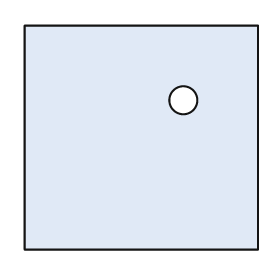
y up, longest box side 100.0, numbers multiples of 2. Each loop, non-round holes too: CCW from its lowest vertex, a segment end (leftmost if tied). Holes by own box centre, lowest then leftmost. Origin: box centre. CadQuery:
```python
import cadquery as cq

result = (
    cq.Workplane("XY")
    .moveTo(-50.0, -48.0)
    .lineTo(50.0, -48.0)
    .lineTo(50.0, 48.0)
    .lineTo(-50.0, 48.0)
    .close()
    .moveTo(18.0, 16.0)
    .circle(6.0)
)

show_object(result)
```